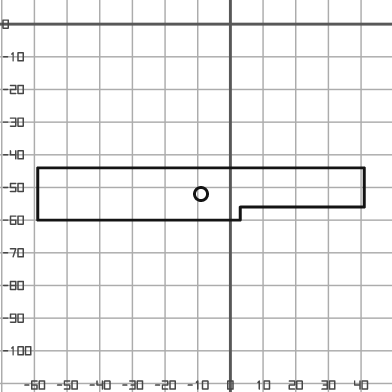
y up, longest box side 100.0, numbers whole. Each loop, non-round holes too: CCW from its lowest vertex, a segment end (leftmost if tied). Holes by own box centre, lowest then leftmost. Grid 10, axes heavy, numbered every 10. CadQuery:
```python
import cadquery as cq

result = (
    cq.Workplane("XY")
    .moveTo(-59.0, -60.0)
    .lineTo(3.0, -60.0)
    .lineTo(3.0, -56.0)
    .lineTo(41.0, -56.0)
    .lineTo(41.0, -44.0)
    .lineTo(-59.0, -44.0)
    .close()
    .moveTo(-9.0, -52.0)
    .circle(2.0)
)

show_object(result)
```